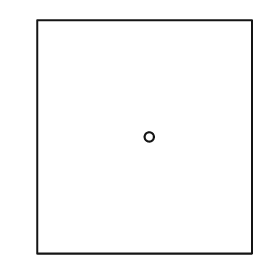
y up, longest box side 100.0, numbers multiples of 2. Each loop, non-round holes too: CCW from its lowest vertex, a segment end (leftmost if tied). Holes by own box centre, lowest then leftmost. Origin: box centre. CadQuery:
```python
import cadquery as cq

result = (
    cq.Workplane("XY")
    .moveTo(-46.0, -50.0)
    .lineTo(46.0, -50.0)
    .lineTo(46.0, 50.0)
    .lineTo(-46.0, 50.0)
    .close()
    .moveTo(2.0, 0.0)
    .circle(2.0)
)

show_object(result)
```